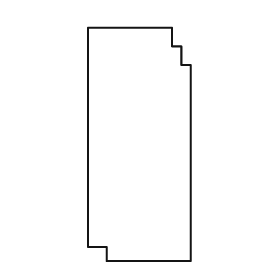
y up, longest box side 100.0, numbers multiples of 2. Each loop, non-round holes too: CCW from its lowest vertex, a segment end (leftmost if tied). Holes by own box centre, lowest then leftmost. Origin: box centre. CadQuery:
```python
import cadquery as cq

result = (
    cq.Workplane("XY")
    .moveTo(-14.0, -50.0)
    .lineTo(22.0, -50.0)
    .lineTo(22.0, 34.0)
    .lineTo(18.0, 34.0)
    .lineTo(18.0, 42.0)
    .lineTo(14.0, 42.0)
    .lineTo(14.0, 50.0)
    .lineTo(-22.0, 50.0)
    .lineTo(-22.0, -44.0)
    .lineTo(-14.0, -44.0)
    .close()
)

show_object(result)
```